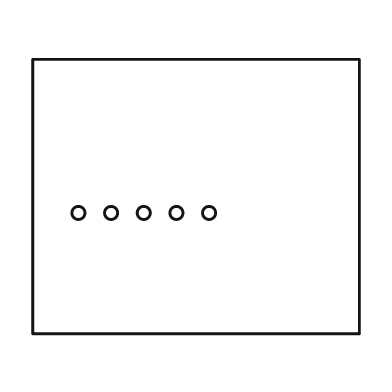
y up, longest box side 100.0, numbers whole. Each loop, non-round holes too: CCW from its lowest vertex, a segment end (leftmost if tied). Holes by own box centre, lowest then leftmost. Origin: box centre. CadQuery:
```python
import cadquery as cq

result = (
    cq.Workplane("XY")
    .moveTo(-50.0, -42.0)
    .lineTo(50.0, -42.0)
    .lineTo(50.0, 42.0)
    .lineTo(-50.0, 42.0)
    .close()
    .moveTo(-36.0, -5.0)
    .circle(2.0)
    .moveTo(-26.0, -5.0)
    .circle(2.0)
    .moveTo(-16.0, -5.0)
    .circle(2.0)
    .moveTo(-6.0, -5.0)
    .circle(2.0)
    .moveTo(4.0, -5.0)
    .circle(2.0)
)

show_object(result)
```